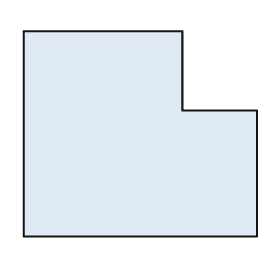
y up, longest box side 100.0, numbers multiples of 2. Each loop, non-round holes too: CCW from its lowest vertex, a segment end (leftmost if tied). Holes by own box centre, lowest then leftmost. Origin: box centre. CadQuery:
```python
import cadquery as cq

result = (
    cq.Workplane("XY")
    .moveTo(-50.0, -44.0)
    .lineTo(50.0, -44.0)
    .lineTo(50.0, 10.0)
    .lineTo(18.0, 10.0)
    .lineTo(18.0, 44.0)
    .lineTo(-50.0, 44.0)
    .close()
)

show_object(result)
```